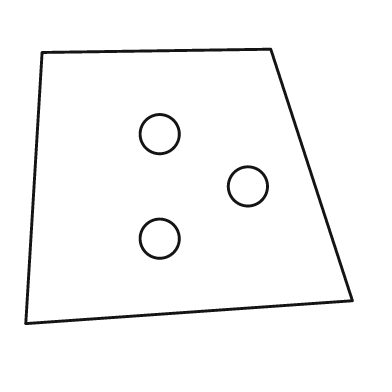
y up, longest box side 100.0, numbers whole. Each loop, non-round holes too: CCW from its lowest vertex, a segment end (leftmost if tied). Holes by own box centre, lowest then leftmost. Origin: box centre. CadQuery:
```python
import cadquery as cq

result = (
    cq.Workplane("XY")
    .moveTo(-50.0, -42.0)
    .lineTo(50.0, -35.0)
    .lineTo(25.0, 42.0)
    .lineTo(-45.0, 41.0)
    .close()
    .moveTo(-9.0, -16.0)
    .circle(6.0)
    .moveTo(18.0, 0.0)
    .circle(6.0)
    .moveTo(-9.0, 16.0)
    .circle(6.0)
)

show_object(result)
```